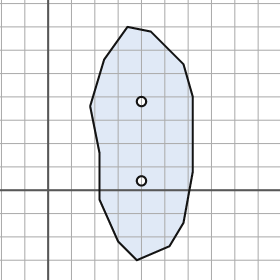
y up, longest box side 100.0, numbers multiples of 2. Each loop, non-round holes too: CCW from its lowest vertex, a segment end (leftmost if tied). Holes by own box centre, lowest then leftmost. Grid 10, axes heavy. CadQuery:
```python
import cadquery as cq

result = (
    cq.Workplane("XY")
    .moveTo(38.0, -30.0)
    .lineTo(52.0, -24.0)
    .lineTo(58.0, -14.0)
    .lineTo(62.0, 8.0)
    .lineTo(62.0, 40.0)
    .lineTo(58.0, 54.0)
    .lineTo(44.0, 68.0)
    .lineTo(34.0, 70.0)
    .lineTo(24.0, 56.0)
    .lineTo(18.0, 36.0)
    .lineTo(22.0, 16.0)
    .lineTo(22.0, -4.0)
    .lineTo(30.0, -22.0)
    .close()
    .moveTo(40.0, 4.0)
    .circle(2.0)
    .moveTo(40.0, 38.0)
    .circle(2.0)
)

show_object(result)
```